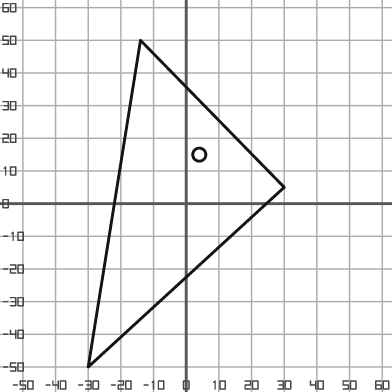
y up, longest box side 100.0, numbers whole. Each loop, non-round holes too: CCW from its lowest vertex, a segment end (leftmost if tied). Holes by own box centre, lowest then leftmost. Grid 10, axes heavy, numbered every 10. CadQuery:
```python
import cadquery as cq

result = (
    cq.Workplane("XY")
    .moveTo(-30.0, -50.0)
    .lineTo(30.0, 5.0)
    .lineTo(-14.0, 50.0)
    .close()
    .moveTo(4.0, 15.0)
    .circle(2.0)
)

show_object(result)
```